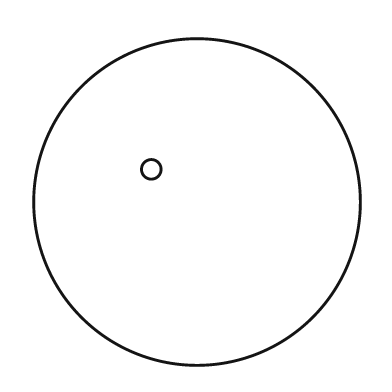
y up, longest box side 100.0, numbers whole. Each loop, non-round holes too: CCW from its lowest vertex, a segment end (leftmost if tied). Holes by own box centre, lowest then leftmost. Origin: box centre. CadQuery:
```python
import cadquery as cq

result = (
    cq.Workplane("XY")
    .moveTo(0.0, 0.0)
    .circle(50.0)
    .moveTo(-14.0, 10.0)
    .circle(3.0)
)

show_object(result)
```